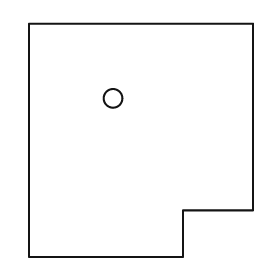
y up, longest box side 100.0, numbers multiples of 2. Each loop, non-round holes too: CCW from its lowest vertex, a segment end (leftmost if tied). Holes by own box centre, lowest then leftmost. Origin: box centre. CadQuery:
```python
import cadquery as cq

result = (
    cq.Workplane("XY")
    .moveTo(-48.0, -50.0)
    .lineTo(18.0, -50.0)
    .lineTo(18.0, -30.0)
    .lineTo(48.0, -30.0)
    .lineTo(48.0, 50.0)
    .lineTo(-48.0, 50.0)
    .close()
    .moveTo(-12.0, 18.0)
    .circle(4.0)
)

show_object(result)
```